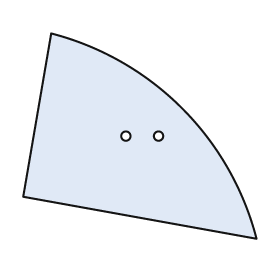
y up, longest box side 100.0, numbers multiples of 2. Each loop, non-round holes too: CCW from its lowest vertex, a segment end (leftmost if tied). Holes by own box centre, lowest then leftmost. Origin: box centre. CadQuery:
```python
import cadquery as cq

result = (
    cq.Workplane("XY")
    .moveTo(50.0, -44.0)
    .threePointArc((18.0, 12.0), (-38.0, 44.0))
    .lineTo(-50.0, -26.0)
    .close()
    .moveTo(-6.0, 0.0)
    .circle(2.0)
    .moveTo(8.0, 0.0)
    .circle(2.0)
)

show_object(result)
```